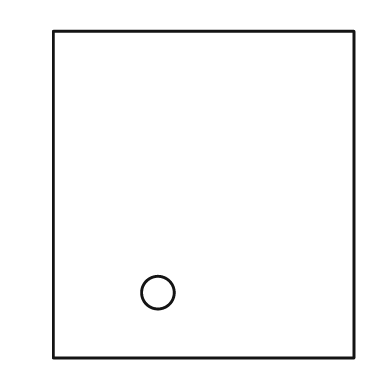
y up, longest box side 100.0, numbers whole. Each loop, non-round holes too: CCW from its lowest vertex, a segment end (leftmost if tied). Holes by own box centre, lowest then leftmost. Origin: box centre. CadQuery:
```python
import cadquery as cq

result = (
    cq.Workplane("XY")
    .moveTo(-46.0, -50.0)
    .lineTo(46.0, -50.0)
    .lineTo(46.0, 50.0)
    .lineTo(-46.0, 50.0)
    .close()
    .moveTo(-14.0, -30.0)
    .circle(5.0)
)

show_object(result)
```